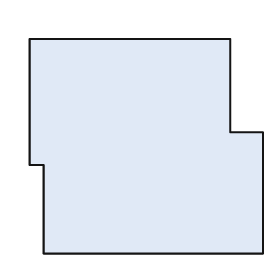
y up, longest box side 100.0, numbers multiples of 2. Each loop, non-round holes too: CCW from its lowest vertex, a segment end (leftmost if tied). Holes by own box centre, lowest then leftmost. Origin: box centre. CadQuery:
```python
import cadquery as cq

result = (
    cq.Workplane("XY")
    .moveTo(-44.0, -46.0)
    .lineTo(50.0, -46.0)
    .lineTo(50.0, 6.0)
    .lineTo(36.0, 6.0)
    .lineTo(36.0, 46.0)
    .lineTo(-50.0, 46.0)
    .lineTo(-50.0, -8.0)
    .lineTo(-44.0, -8.0)
    .close()
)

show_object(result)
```